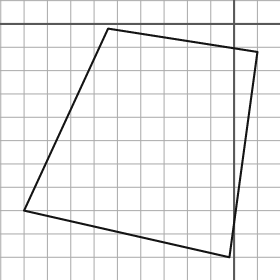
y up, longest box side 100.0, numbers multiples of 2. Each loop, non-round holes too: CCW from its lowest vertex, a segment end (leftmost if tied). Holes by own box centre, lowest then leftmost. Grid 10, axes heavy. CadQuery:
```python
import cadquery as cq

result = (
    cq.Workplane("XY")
    .moveTo(-2.0, -100.0)
    .lineTo(10.0, -12.0)
    .lineTo(-54.0, -2.0)
    .lineTo(-90.0, -80.0)
    .close()
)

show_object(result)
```